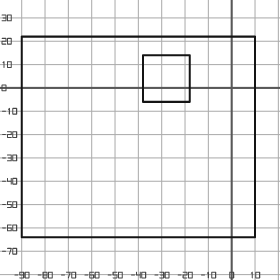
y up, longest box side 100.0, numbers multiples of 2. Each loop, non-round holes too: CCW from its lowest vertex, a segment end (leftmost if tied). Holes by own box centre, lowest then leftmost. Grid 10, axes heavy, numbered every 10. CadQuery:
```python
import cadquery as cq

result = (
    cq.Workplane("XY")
    .moveTo(-90.0, -64.0)
    .lineTo(10.0, -64.0)
    .lineTo(10.0, 22.0)
    .lineTo(-90.0, 22.0)
    .close()
    .moveTo(-38.0, -6.0)
    .lineTo(-18.0, -6.0)
    .lineTo(-18.0, 14.0)
    .lineTo(-38.0, 14.0)
    .close()
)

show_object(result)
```